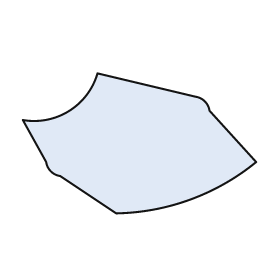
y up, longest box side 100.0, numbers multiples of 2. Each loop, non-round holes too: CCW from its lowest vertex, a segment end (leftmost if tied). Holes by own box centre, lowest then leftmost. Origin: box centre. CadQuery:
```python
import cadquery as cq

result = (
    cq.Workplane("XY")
    .moveTo(-10.0, -30.0)
    .threePointArc((22.0, -24.0), (50.0, -8.0))
    .lineTo(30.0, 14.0)
    .threePointArc((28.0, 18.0), (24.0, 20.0))
    .lineTo(-18.0, 30.0)
    .threePointArc((-30.0, 14.0), (-50.0, 10.0))
    .lineTo(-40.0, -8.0)
    .threePointArc((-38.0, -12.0), (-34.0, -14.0))
    .close()
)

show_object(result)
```